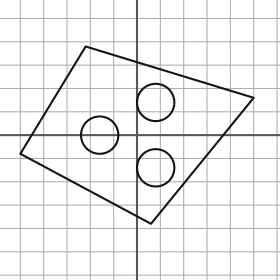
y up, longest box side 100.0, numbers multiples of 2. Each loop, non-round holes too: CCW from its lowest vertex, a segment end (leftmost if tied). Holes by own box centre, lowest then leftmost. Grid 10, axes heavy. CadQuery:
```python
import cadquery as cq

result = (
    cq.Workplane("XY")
    .moveTo(6.0, -38.0)
    .lineTo(50.0, 16.0)
    .lineTo(-22.0, 38.0)
    .lineTo(-50.0, -8.0)
    .close()
    .moveTo(8.0, -14.0)
    .circle(8.0)
    .moveTo(-16.0, 0.0)
    .circle(8.0)
    .moveTo(8.0, 14.0)
    .circle(8.0)
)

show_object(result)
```